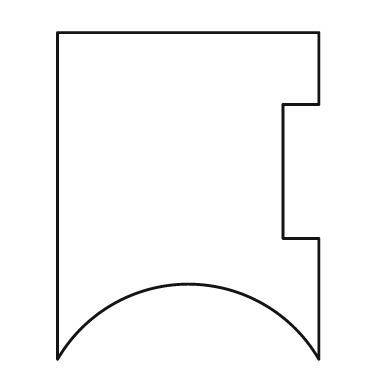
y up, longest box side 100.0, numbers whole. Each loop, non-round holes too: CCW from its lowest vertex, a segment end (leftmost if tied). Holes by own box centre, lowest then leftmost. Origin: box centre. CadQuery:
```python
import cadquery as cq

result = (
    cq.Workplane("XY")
    .moveTo(-40.0, -50.0)
    .threePointArc((0.0, -27.0), (40.0, -50.0))
    .lineTo(40.0, -13.0)
    .lineTo(29.0, -13.0)
    .lineTo(29.0, 28.0)
    .lineTo(40.0, 28.0)
    .lineTo(40.0, 50.0)
    .lineTo(-40.0, 50.0)
    .close()
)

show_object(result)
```